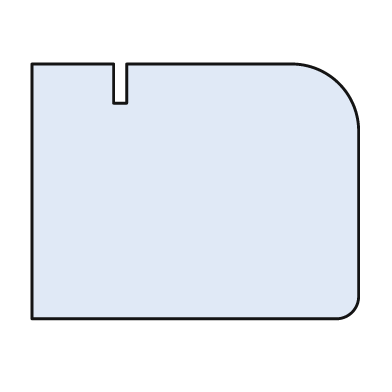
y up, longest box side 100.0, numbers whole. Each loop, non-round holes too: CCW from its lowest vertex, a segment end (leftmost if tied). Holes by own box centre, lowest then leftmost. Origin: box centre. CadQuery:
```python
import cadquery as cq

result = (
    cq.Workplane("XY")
    .moveTo(-50.0, -39.0)
    .lineTo(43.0, -39.0)
    .threePointArc((48.0, -37.0), (50.0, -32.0))
    .lineTo(50.0, 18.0)
    .threePointArc((44.0, 33.0), (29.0, 39.0))
    .lineTo(-21.0, 39.0)
    .lineTo(-21.0, 27.0)
    .lineTo(-25.0, 27.0)
    .lineTo(-25.0, 39.0)
    .lineTo(-50.0, 39.0)
    .close()
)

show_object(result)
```